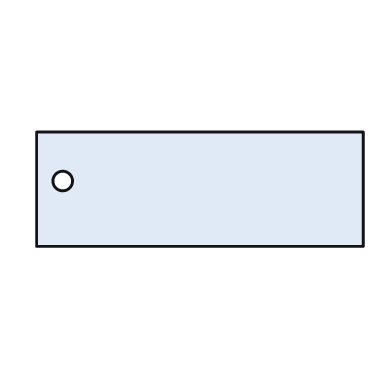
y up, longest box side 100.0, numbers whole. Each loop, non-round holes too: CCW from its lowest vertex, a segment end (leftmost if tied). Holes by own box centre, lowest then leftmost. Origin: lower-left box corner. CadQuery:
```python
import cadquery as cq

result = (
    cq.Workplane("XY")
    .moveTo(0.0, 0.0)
    .lineTo(100.0, 0.0)
    .lineTo(100.0, 35.0)
    .lineTo(0.0, 35.0)
    .close()
    .moveTo(8.0, 20.0)
    .circle(3.0)
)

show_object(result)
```